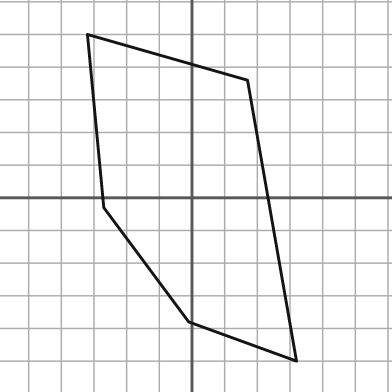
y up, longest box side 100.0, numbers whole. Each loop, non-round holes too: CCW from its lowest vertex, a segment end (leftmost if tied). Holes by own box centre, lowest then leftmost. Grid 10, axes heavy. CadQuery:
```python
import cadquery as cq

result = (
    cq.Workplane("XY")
    .moveTo(32.0, -50.0)
    .lineTo(17.0, 36.0)
    .lineTo(-32.0, 50.0)
    .lineTo(-27.0, -3.0)
    .lineTo(-1.0, -38.0)
    .close()
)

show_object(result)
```